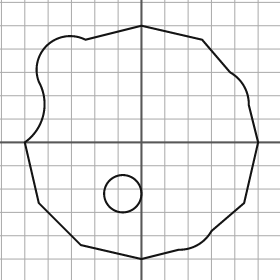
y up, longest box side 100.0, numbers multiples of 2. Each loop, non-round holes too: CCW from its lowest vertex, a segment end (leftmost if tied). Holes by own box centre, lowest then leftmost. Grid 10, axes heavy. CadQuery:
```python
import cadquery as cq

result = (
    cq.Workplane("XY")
    .moveTo(0.0, -50.0)
    .lineTo(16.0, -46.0)
    .threePointArc((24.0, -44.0), (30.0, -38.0))
    .lineTo(44.0, -26.0)
    .lineTo(50.0, 0.0)
    .lineTo(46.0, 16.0)
    .threePointArc((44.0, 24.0), (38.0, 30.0))
    .lineTo(26.0, 44.0)
    .lineTo(0.0, 50.0)
    .lineTo(-24.0, 44.0)
    .threePointArc((-40.0, 42.0), (-44.0, 26.0))
    .threePointArc((-42.0, 12.0), (-50.0, 0.0))
    .lineTo(-44.0, -26.0)
    .lineTo(-26.0, -44.0)
    .close()
    .moveTo(-8.0, -22.0)
    .circle(8.0)
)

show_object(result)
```